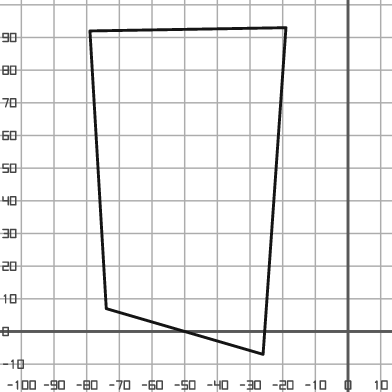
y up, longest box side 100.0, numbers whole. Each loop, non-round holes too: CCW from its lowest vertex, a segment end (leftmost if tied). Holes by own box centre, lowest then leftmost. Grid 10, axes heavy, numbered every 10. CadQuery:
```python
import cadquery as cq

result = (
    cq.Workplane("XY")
    .moveTo(-26.0, -7.0)
    .lineTo(-19.0, 93.0)
    .lineTo(-79.0, 92.0)
    .lineTo(-74.0, 7.0)
    .close()
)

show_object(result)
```